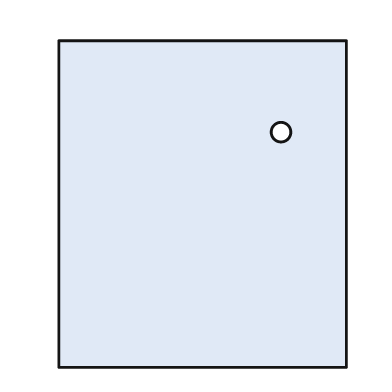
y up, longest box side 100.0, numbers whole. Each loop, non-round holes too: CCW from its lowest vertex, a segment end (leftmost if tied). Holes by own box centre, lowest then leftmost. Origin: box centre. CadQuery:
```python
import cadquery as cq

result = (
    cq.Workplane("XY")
    .moveTo(-44.0, -50.0)
    .lineTo(44.0, -50.0)
    .lineTo(44.0, 50.0)
    .lineTo(-44.0, 50.0)
    .close()
    .moveTo(24.0, 22.0)
    .circle(3.0)
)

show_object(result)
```